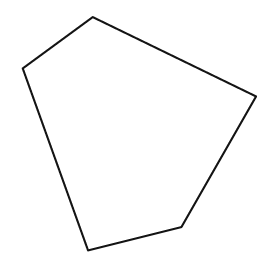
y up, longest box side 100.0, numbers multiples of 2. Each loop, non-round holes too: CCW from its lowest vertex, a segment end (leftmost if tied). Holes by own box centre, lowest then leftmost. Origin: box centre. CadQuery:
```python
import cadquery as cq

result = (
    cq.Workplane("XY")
    .moveTo(-22.0, -50.0)
    .lineTo(18.0, -40.0)
    .lineTo(50.0, 16.0)
    .lineTo(-20.0, 50.0)
    .lineTo(-50.0, 28.0)
    .close()
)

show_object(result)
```